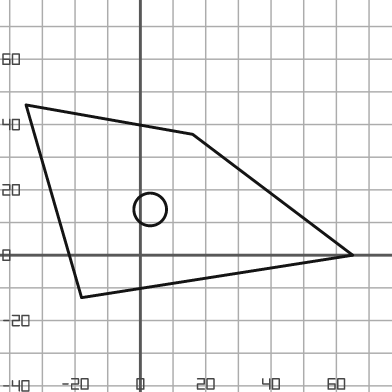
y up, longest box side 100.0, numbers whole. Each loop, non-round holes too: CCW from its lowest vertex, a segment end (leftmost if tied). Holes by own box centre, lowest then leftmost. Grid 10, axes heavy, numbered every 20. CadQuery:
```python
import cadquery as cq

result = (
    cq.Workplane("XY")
    .moveTo(-18.0, -13.0)
    .lineTo(65.0, 0.0)
    .lineTo(16.0, 37.0)
    .lineTo(-35.0, 46.0)
    .close()
    .moveTo(3.0, 14.0)
    .circle(5.0)
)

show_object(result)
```